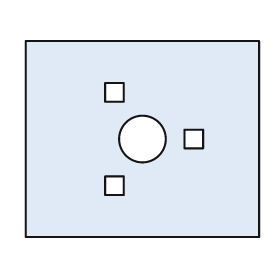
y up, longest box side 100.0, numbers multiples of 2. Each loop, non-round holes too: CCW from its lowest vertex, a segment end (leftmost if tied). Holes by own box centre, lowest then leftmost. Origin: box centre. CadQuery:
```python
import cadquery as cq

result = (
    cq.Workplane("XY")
    .moveTo(-50.0, -42.0)
    .lineTo(50.0, -42.0)
    .lineTo(50.0, 42.0)
    .lineTo(-50.0, 42.0)
    .close()
    .moveTo(-16.0, -24.0)
    .lineTo(-8.0, -24.0)
    .lineTo(-8.0, -16.0)
    .lineTo(-16.0, -16.0)
    .close()
    .moveTo(0.0, 0.0)
    .circle(10.0)
    .moveTo(18.0, -4.0)
    .lineTo(26.0, -4.0)
    .lineTo(26.0, 4.0)
    .lineTo(18.0, 4.0)
    .close()
    .moveTo(-16.0, 16.0)
    .lineTo(-8.0, 16.0)
    .lineTo(-8.0, 24.0)
    .lineTo(-16.0, 24.0)
    .close()
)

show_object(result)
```